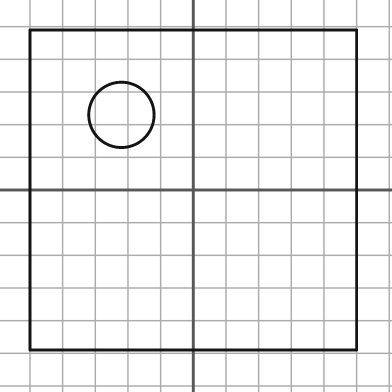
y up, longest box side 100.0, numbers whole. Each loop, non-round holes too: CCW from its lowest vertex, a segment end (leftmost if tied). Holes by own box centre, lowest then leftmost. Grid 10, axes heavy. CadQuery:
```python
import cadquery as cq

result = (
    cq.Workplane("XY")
    .moveTo(-50.0, -49.0)
    .lineTo(50.0, -49.0)
    .lineTo(50.0, 49.0)
    .lineTo(-50.0, 49.0)
    .close()
    .moveTo(-22.0, 23.0)
    .circle(10.0)
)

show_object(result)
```